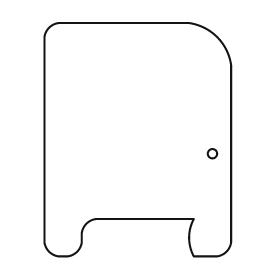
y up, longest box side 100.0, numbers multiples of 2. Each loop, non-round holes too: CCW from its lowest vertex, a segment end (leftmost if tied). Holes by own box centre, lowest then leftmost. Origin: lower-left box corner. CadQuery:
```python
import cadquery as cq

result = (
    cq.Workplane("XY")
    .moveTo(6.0, 0.0)
    .lineTo(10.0, 0.0)
    .threePointArc((14.0, 2.0), (16.0, 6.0))
    .lineTo(16.0, 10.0)
    .threePointArc((18.0, 14.0), (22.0, 16.0))
    .lineTo(64.0, 16.0)
    .threePointArc((62.0, 8.0), (64.0, 0.0))
    .lineTo(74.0, 0.0)
    .threePointArc((78.0, 2.0), (80.0, 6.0))
    .lineTo(80.0, 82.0)
    .threePointArc((74.0, 94.0), (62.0, 100.0))
    .lineTo(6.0, 100.0)
    .threePointArc((2.0, 98.0), (0.0, 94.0))
    .lineTo(0.0, 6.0)
    .threePointArc((2.0, 2.0), (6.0, 0.0))
    .close()
    .moveTo(72.0, 44.0)
    .circle(2.0)
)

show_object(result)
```